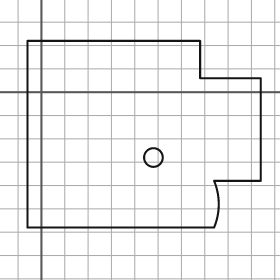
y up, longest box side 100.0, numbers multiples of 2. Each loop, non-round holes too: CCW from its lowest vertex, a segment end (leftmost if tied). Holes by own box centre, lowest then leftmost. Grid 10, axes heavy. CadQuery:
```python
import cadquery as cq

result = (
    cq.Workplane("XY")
    .moveTo(-6.0, -58.0)
    .lineTo(74.0, -58.0)
    .threePointArc((76.0, -48.0), (74.0, -38.0))
    .lineTo(94.0, -38.0)
    .lineTo(94.0, 6.0)
    .lineTo(68.0, 6.0)
    .lineTo(68.0, 22.0)
    .lineTo(-6.0, 22.0)
    .close()
    .moveTo(48.0, -28.0)
    .circle(4.0)
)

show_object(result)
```